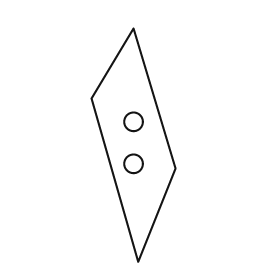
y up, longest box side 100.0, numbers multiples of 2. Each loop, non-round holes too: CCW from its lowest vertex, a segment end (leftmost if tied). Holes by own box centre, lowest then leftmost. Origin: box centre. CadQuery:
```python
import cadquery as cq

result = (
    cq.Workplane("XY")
    .moveTo(2.0, -50.0)
    .lineTo(18.0, -10.0)
    .lineTo(0.0, 50.0)
    .lineTo(-18.0, 20.0)
    .close()
    .moveTo(0.0, -8.0)
    .circle(4.0)
    .moveTo(0.0, 10.0)
    .circle(4.0)
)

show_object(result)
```